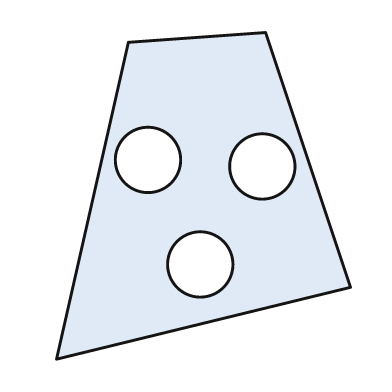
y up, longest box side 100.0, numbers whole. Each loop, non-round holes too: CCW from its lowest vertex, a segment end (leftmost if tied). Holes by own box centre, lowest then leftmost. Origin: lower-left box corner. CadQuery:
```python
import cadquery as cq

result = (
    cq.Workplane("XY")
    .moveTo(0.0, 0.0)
    .lineTo(90.0, 22.0)
    .lineTo(64.0, 100.0)
    .lineTo(22.0, 97.0)
    .close()
    .moveTo(44.0, 29.0)
    .circle(10.0)
    .moveTo(63.0, 59.0)
    .circle(10.0)
    .moveTo(28.0, 61.0)
    .circle(10.0)
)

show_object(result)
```